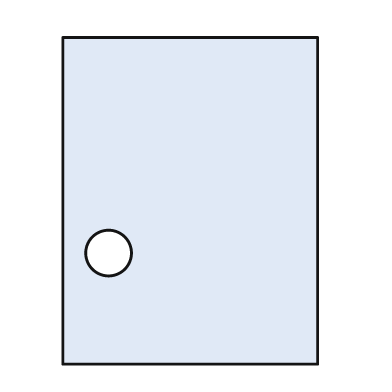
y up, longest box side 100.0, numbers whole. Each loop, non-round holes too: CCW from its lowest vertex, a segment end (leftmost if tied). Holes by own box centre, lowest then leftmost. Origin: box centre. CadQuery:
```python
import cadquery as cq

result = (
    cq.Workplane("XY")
    .moveTo(-39.0, -50.0)
    .lineTo(39.0, -50.0)
    .lineTo(39.0, 50.0)
    .lineTo(-39.0, 50.0)
    .close()
    .moveTo(-25.0, -16.0)
    .circle(7.0)
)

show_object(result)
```